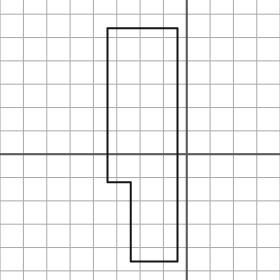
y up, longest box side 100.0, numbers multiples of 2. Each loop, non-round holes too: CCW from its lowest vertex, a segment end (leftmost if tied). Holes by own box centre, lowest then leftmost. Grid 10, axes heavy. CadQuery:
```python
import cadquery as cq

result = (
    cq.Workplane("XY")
    .moveTo(-24.0, -46.0)
    .lineTo(-4.0, -46.0)
    .lineTo(-4.0, 54.0)
    .lineTo(-34.0, 54.0)
    .lineTo(-34.0, -12.0)
    .lineTo(-24.0, -12.0)
    .close()
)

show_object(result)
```